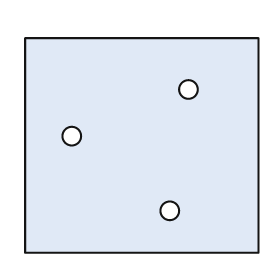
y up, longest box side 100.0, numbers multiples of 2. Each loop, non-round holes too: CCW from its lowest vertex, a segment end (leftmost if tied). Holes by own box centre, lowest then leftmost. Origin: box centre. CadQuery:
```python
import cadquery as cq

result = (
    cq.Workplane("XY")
    .moveTo(-50.0, -46.0)
    .lineTo(50.0, -46.0)
    .lineTo(50.0, 46.0)
    .lineTo(-50.0, 46.0)
    .close()
    .moveTo(12.0, -28.0)
    .circle(4.0)
    .moveTo(-30.0, 4.0)
    .circle(4.0)
    .moveTo(20.0, 24.0)
    .circle(4.0)
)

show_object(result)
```